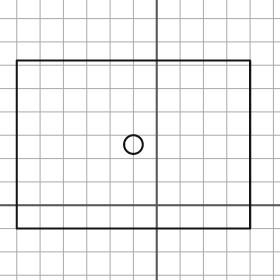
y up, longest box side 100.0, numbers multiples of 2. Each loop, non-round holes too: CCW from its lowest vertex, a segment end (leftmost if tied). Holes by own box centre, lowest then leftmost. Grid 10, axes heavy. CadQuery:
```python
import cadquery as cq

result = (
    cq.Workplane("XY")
    .moveTo(-60.0, -10.0)
    .lineTo(40.0, -10.0)
    .lineTo(40.0, 62.0)
    .lineTo(-60.0, 62.0)
    .close()
    .moveTo(-10.0, 26.0)
    .circle(4.0)
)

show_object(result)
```